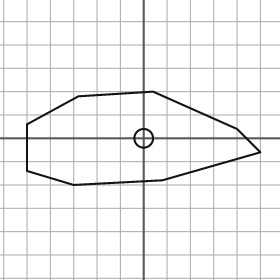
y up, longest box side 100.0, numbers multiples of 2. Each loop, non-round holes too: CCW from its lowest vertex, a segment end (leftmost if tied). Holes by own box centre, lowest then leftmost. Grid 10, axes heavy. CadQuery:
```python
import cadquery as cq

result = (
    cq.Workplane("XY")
    .moveTo(-30.0, -20.0)
    .lineTo(8.0, -18.0)
    .lineTo(50.0, -6.0)
    .lineTo(40.0, 4.0)
    .lineTo(4.0, 20.0)
    .lineTo(-28.0, 18.0)
    .lineTo(-50.0, 6.0)
    .lineTo(-50.0, -14.0)
    .close()
    .moveTo(0.0, 0.0)
    .circle(4.0)
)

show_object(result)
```